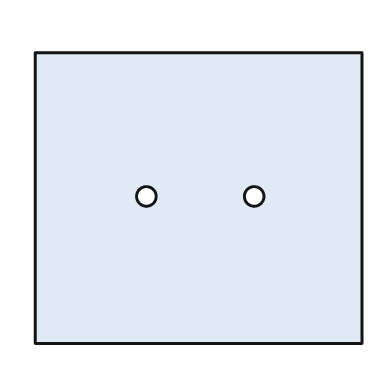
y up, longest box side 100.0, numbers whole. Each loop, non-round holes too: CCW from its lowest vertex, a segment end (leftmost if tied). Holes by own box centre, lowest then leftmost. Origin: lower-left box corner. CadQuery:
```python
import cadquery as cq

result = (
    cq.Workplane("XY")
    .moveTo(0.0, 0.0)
    .lineTo(100.0, 0.0)
    .lineTo(100.0, 89.0)
    .lineTo(0.0, 89.0)
    .close()
    .moveTo(34.0, 45.0)
    .circle(3.0)
    .moveTo(67.0, 45.0)
    .circle(3.0)
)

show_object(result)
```